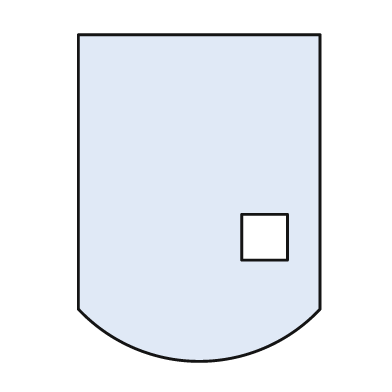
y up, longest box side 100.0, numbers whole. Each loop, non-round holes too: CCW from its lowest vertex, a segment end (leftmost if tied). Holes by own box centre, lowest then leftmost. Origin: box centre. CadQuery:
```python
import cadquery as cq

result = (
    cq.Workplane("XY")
    .moveTo(-37.0, -34.0)
    .threePointArc((0.0, -50.0), (37.0, -34.0))
    .lineTo(37.0, 50.0)
    .lineTo(-37.0, 50.0)
    .close()
    .moveTo(13.0, -19.0)
    .lineTo(27.0, -19.0)
    .lineTo(27.0, -5.0)
    .lineTo(13.0, -5.0)
    .close()
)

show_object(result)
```